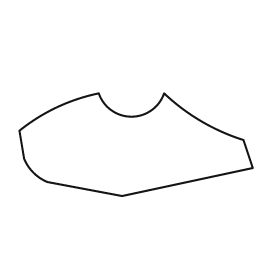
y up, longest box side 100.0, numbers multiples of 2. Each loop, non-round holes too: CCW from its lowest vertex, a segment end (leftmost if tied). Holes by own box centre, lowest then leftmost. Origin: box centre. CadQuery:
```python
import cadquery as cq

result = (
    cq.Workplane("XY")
    .moveTo(-6.0, -22.0)
    .lineTo(50.0, -10.0)
    .lineTo(46.0, 2.0)
    .threePointArc((28.0, 10.0), (12.0, 22.0))
    .threePointArc((-2.0, 12.0), (-16.0, 22.0))
    .threePointArc((-34.0, 16.0), (-50.0, 6.0))
    .lineTo(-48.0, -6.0)
    .threePointArc((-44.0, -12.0), (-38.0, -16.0))
    .close()
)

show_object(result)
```